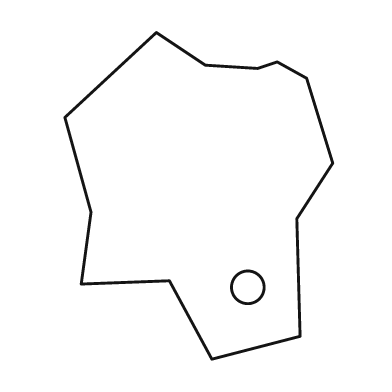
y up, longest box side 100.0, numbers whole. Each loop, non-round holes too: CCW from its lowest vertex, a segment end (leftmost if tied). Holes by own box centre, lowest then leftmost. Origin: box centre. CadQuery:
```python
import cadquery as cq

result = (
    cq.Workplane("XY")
    .moveTo(4.0, -50.0)
    .lineTo(31.0, -43.0)
    .lineTo(30.0, -7.0)
    .lineTo(41.0, 10.0)
    .lineTo(33.0, 36.0)
    .lineTo(24.0, 41.0)
    .lineTo(18.0, 39.0)
    .lineTo(2.0, 40.0)
    .lineTo(-13.0, 50.0)
    .lineTo(-41.0, 24.0)
    .lineTo(-33.0, -5.0)
    .lineTo(-36.0, -27.0)
    .lineTo(-9.0, -26.0)
    .close()
    .moveTo(15.0, -28.0)
    .circle(5.0)
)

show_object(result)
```